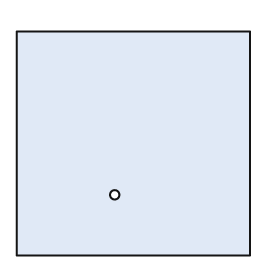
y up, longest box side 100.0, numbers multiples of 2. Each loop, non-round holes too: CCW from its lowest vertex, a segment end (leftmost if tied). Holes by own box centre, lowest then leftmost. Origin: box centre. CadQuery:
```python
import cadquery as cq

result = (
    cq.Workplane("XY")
    .moveTo(-50.0, -48.0)
    .lineTo(50.0, -48.0)
    .lineTo(50.0, 48.0)
    .lineTo(-50.0, 48.0)
    .close()
    .moveTo(-8.0, -22.0)
    .circle(2.0)
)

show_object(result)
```